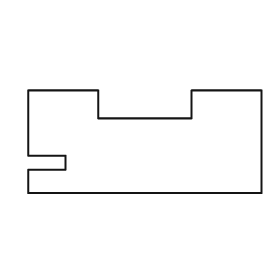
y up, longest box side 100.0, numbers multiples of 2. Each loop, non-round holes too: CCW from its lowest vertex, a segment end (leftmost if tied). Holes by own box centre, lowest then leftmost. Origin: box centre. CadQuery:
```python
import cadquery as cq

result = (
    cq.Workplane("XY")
    .moveTo(-50.0, -22.0)
    .lineTo(50.0, -22.0)
    .lineTo(50.0, 22.0)
    .lineTo(20.0, 22.0)
    .lineTo(20.0, 10.0)
    .lineTo(-20.0, 10.0)
    .lineTo(-20.0, 22.0)
    .lineTo(-50.0, 22.0)
    .lineTo(-50.0, -6.0)
    .lineTo(-34.0, -6.0)
    .lineTo(-34.0, -12.0)
    .lineTo(-50.0, -12.0)
    .close()
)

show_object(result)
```